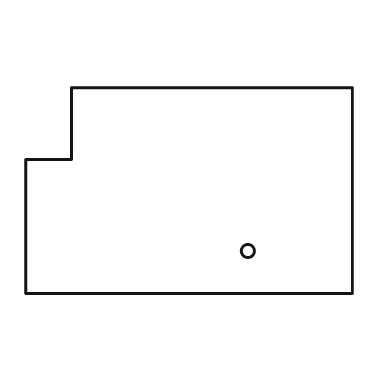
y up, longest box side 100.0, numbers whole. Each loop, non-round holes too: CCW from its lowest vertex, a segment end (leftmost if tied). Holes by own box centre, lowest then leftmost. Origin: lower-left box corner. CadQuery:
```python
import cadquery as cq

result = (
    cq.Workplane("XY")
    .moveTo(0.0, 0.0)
    .lineTo(100.0, 0.0)
    .lineTo(100.0, 63.0)
    .lineTo(14.0, 63.0)
    .lineTo(14.0, 41.0)
    .lineTo(0.0, 41.0)
    .close()
    .moveTo(68.0, 13.0)
    .circle(2.0)
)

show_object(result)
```